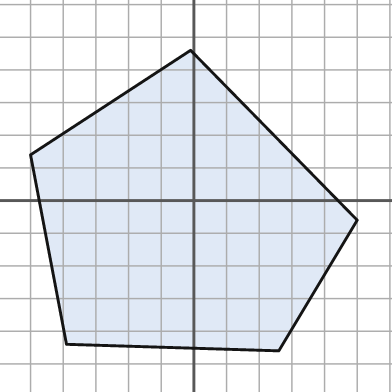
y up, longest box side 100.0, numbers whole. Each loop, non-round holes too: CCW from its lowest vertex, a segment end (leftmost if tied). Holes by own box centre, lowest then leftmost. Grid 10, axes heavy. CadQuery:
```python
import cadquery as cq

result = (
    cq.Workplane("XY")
    .moveTo(26.0, -46.0)
    .lineTo(50.0, -6.0)
    .lineTo(-1.0, 46.0)
    .lineTo(-50.0, 14.0)
    .lineTo(-39.0, -44.0)
    .close()
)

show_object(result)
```